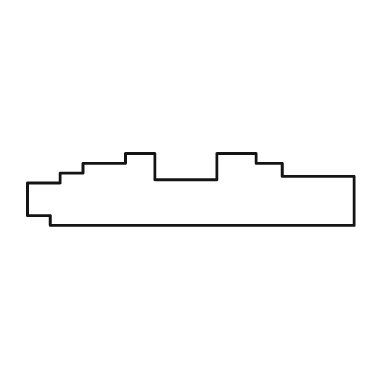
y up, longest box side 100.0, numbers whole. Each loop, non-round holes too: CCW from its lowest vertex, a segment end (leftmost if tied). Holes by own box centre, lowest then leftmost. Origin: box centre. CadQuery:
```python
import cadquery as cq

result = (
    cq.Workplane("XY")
    .moveTo(-43.0, -11.0)
    .lineTo(50.0, -11.0)
    .lineTo(50.0, 4.0)
    .lineTo(28.0, 4.0)
    .lineTo(28.0, 8.0)
    .lineTo(20.0, 8.0)
    .lineTo(20.0, 11.0)
    .lineTo(8.0, 11.0)
    .lineTo(8.0, 3.0)
    .lineTo(-11.0, 3.0)
    .lineTo(-11.0, 11.0)
    .lineTo(-20.0, 11.0)
    .lineTo(-20.0, 8.0)
    .lineTo(-33.0, 8.0)
    .lineTo(-33.0, 5.0)
    .lineTo(-40.0, 5.0)
    .lineTo(-40.0, 2.0)
    .lineTo(-50.0, 2.0)
    .lineTo(-50.0, -8.0)
    .lineTo(-43.0, -8.0)
    .close()
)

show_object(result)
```